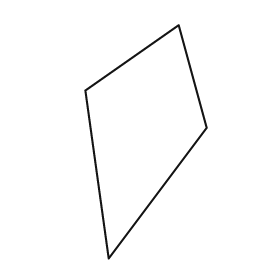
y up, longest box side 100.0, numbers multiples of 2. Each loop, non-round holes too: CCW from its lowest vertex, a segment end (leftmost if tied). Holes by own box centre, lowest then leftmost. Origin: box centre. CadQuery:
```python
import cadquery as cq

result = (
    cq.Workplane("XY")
    .moveTo(-16.0, -50.0)
    .lineTo(26.0, 6.0)
    .lineTo(14.0, 50.0)
    .lineTo(-26.0, 22.0)
    .close()
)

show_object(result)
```